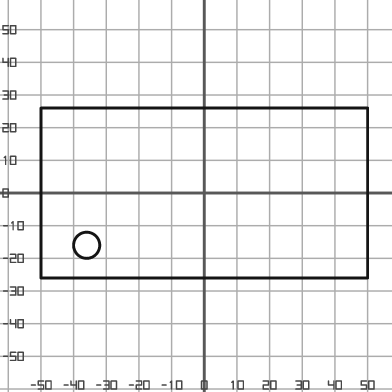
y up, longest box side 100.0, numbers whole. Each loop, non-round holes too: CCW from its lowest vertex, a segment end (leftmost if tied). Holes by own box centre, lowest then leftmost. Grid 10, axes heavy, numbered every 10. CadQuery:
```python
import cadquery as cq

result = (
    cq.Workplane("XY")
    .moveTo(-50.0, -26.0)
    .lineTo(50.0, -26.0)
    .lineTo(50.0, 26.0)
    .lineTo(-50.0, 26.0)
    .close()
    .moveTo(-36.0, -16.0)
    .circle(4.0)
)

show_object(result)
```